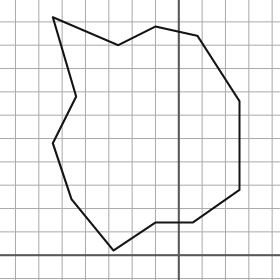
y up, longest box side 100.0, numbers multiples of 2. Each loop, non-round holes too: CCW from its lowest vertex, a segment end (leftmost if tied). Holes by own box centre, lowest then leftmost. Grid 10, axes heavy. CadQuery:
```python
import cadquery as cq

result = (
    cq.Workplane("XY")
    .moveTo(-28.0, 2.0)
    .lineTo(-10.0, 14.0)
    .lineTo(6.0, 14.0)
    .lineTo(26.0, 28.0)
    .lineTo(26.0, 66.0)
    .lineTo(8.0, 94.0)
    .lineTo(-10.0, 98.0)
    .lineTo(-26.0, 90.0)
    .lineTo(-54.0, 102.0)
    .lineTo(-44.0, 68.0)
    .lineTo(-54.0, 48.0)
    .lineTo(-46.0, 24.0)
    .close()
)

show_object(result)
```